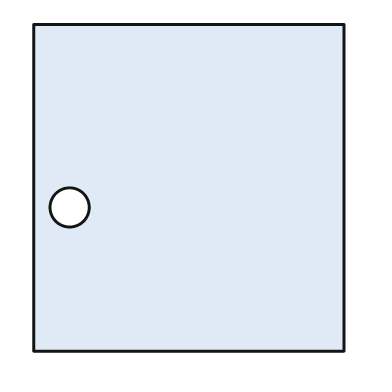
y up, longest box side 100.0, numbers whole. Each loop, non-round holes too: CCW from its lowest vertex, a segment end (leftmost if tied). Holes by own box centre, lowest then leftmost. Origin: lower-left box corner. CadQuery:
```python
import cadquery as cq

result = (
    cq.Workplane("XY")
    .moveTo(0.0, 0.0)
    .lineTo(95.0, 0.0)
    .lineTo(95.0, 100.0)
    .lineTo(0.0, 100.0)
    .close()
    .moveTo(11.0, 44.0)
    .circle(6.0)
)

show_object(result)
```